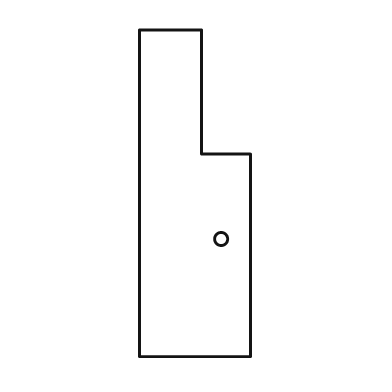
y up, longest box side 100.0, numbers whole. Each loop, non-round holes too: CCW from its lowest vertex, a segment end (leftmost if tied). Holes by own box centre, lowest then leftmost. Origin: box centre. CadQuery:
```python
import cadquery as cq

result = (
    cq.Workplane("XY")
    .moveTo(-17.0, -50.0)
    .lineTo(17.0, -50.0)
    .lineTo(17.0, 12.0)
    .lineTo(2.0, 12.0)
    .lineTo(2.0, 50.0)
    .lineTo(-17.0, 50.0)
    .close()
    .moveTo(8.0, -14.0)
    .circle(2.0)
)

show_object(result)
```